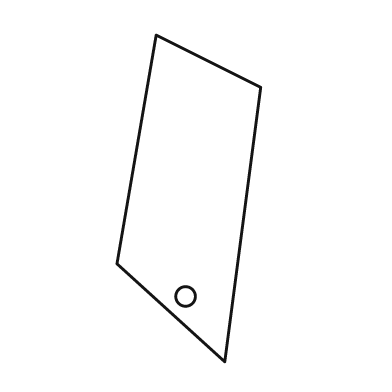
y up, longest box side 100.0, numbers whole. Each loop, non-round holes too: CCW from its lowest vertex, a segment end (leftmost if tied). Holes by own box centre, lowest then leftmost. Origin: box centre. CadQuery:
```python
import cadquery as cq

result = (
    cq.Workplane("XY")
    .moveTo(11.0, -50.0)
    .lineTo(22.0, 34.0)
    .lineTo(-10.0, 50.0)
    .lineTo(-22.0, -20.0)
    .close()
    .moveTo(-1.0, -30.0)
    .circle(3.0)
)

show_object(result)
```